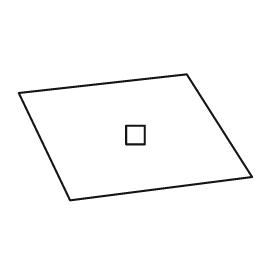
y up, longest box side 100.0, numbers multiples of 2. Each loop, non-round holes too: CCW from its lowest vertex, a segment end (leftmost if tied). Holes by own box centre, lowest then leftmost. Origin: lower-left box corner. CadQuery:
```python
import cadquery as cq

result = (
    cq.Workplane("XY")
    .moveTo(22.0, 0.0)
    .lineTo(100.0, 10.0)
    .lineTo(72.0, 54.0)
    .lineTo(0.0, 46.0)
    .close()
    .moveTo(46.0, 24.0)
    .lineTo(54.0, 24.0)
    .lineTo(54.0, 32.0)
    .lineTo(46.0, 32.0)
    .close()
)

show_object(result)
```